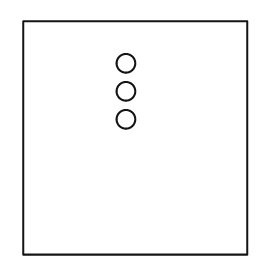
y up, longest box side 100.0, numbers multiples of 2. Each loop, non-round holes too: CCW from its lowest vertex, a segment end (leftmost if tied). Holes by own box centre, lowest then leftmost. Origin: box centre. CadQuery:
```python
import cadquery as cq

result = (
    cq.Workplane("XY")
    .moveTo(-48.0, -50.0)
    .lineTo(48.0, -50.0)
    .lineTo(48.0, 50.0)
    .lineTo(-48.0, 50.0)
    .close()
    .moveTo(-4.0, 8.0)
    .circle(4.0)
    .moveTo(-4.0, 20.0)
    .circle(4.0)
    .moveTo(-4.0, 32.0)
    .circle(4.0)
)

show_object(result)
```